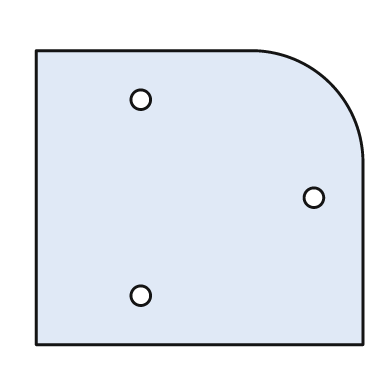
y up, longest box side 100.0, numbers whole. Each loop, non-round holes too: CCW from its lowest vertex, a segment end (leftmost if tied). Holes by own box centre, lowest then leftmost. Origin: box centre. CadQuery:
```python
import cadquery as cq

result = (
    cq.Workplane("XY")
    .moveTo(-50.0, -45.0)
    .lineTo(50.0, -45.0)
    .lineTo(50.0, 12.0)
    .threePointArc((40.0, 35.0), (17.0, 45.0))
    .lineTo(-50.0, 45.0)
    .close()
    .moveTo(-18.0, -30.0)
    .circle(3.0)
    .moveTo(35.0, 0.0)
    .circle(3.0)
    .moveTo(-18.0, 30.0)
    .circle(3.0)
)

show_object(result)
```